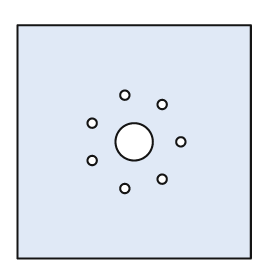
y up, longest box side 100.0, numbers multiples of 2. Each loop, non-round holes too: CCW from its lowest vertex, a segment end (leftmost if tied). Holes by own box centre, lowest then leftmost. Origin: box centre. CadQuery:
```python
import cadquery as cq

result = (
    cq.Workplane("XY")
    .moveTo(-50.0, -50.0)
    .lineTo(50.0, -50.0)
    .lineTo(50.0, 50.0)
    .lineTo(-50.0, 50.0)
    .close()
    .moveTo(-4.0, -20.0)
    .circle(2.0)
    .moveTo(12.0, -16.0)
    .circle(2.0)
    .moveTo(-18.0, -8.0)
    .circle(2.0)
    .moveTo(0.0, 0.0)
    .circle(8.0)
    .moveTo(20.0, 0.0)
    .circle(2.0)
    .moveTo(-18.0, 8.0)
    .circle(2.0)
    .moveTo(12.0, 16.0)
    .circle(2.0)
    .moveTo(-4.0, 20.0)
    .circle(2.0)
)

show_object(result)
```